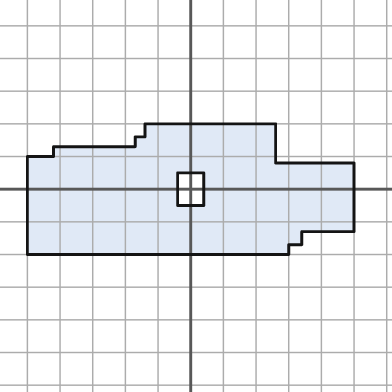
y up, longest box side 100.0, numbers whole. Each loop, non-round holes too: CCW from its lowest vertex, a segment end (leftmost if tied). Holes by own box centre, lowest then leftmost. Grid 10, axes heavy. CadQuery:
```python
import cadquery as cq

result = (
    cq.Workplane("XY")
    .moveTo(-50.0, -20.0)
    .lineTo(30.0, -20.0)
    .lineTo(30.0, -17.0)
    .lineTo(34.0, -17.0)
    .lineTo(34.0, -13.0)
    .lineTo(50.0, -13.0)
    .lineTo(50.0, 8.0)
    .lineTo(26.0, 8.0)
    .lineTo(26.0, 20.0)
    .lineTo(-14.0, 20.0)
    .lineTo(-14.0, 16.0)
    .lineTo(-17.0, 16.0)
    .lineTo(-17.0, 13.0)
    .lineTo(-42.0, 13.0)
    .lineTo(-42.0, 10.0)
    .lineTo(-50.0, 10.0)
    .close()
    .moveTo(-4.0, -5.0)
    .lineTo(4.0, -5.0)
    .lineTo(4.0, 5.0)
    .lineTo(-4.0, 5.0)
    .close()
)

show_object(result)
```